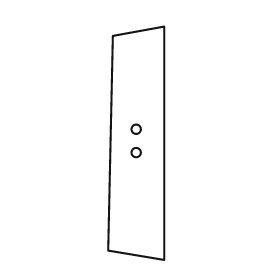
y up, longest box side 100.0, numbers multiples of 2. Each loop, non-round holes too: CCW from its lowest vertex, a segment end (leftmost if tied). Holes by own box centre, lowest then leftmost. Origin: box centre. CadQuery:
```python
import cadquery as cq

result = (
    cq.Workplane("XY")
    .moveTo(12.0, -50.0)
    .lineTo(12.0, 50.0)
    .lineTo(-10.0, 46.0)
    .lineTo(-12.0, -46.0)
    .close()
    .moveTo(0.0, -4.0)
    .circle(2.0)
    .moveTo(0.0, 6.0)
    .circle(2.0)
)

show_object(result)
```